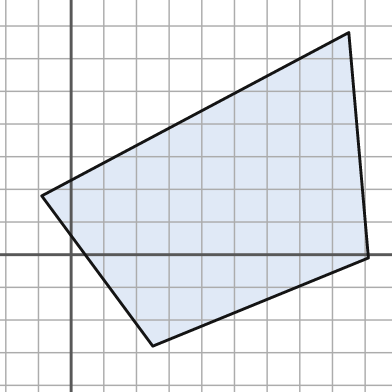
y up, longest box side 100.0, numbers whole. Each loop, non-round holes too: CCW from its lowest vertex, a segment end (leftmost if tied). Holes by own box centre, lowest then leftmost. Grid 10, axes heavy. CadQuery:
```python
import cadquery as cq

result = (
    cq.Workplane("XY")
    .moveTo(25.0, -28.0)
    .lineTo(91.0, -1.0)
    .lineTo(85.0, 68.0)
    .lineTo(-9.0, 18.0)
    .close()
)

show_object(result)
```